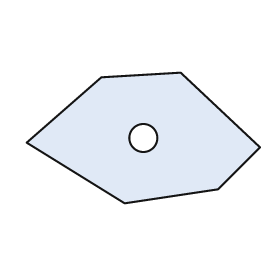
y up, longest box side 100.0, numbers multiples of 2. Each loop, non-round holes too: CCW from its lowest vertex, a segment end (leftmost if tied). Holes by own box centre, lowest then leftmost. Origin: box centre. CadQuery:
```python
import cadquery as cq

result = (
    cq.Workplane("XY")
    .moveTo(-8.0, -28.0)
    .lineTo(32.0, -22.0)
    .lineTo(50.0, -4.0)
    .lineTo(16.0, 28.0)
    .lineTo(-18.0, 26.0)
    .lineTo(-50.0, -2.0)
    .close()
    .moveTo(0.0, 0.0)
    .circle(6.0)
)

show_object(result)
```